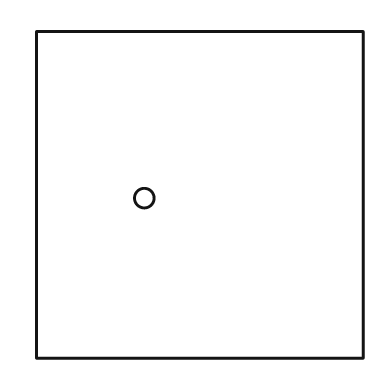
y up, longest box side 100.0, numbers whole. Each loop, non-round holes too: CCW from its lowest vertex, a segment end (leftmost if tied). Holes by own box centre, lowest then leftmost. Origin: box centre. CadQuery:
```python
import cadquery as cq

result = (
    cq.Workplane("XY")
    .moveTo(-50.0, -50.0)
    .lineTo(50.0, -50.0)
    .lineTo(50.0, 50.0)
    .lineTo(-50.0, 50.0)
    .close()
    .moveTo(-17.0, -1.0)
    .circle(3.0)
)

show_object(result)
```